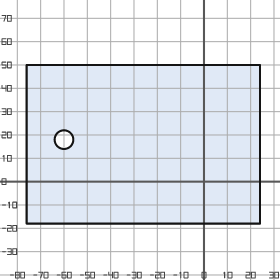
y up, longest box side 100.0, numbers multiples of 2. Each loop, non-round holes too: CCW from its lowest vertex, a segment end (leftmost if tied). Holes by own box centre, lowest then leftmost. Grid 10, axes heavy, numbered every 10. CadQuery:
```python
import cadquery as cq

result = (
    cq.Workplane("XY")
    .moveTo(-76.0, -18.0)
    .lineTo(24.0, -18.0)
    .lineTo(24.0, 50.0)
    .lineTo(-76.0, 50.0)
    .close()
    .moveTo(-60.0, 18.0)
    .circle(4.0)
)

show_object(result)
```